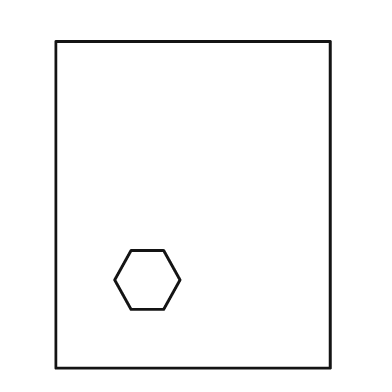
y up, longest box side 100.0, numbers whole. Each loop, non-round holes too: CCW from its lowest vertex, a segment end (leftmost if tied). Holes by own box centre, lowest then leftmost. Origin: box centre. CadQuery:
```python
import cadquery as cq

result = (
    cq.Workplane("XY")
    .moveTo(-42.0, -50.0)
    .lineTo(42.0, -50.0)
    .lineTo(42.0, 50.0)
    .lineTo(-42.0, 50.0)
    .close()
    .moveTo(-19.0, -32.0)
    .lineTo(-9.0, -32.0)
    .lineTo(-4.0, -23.0)
    .lineTo(-9.0, -14.0)
    .lineTo(-19.0, -14.0)
    .lineTo(-24.0, -23.0)
    .close()
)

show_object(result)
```